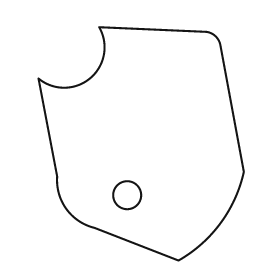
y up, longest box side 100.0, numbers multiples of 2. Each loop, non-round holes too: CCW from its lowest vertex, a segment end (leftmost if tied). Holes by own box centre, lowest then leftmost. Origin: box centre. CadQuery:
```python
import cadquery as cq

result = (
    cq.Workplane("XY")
    .moveTo(16.0, -50.0)
    .threePointArc((34.0, -34.0), (44.0, -12.0))
    .lineTo(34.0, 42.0)
    .threePointArc((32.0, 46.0), (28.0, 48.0))
    .lineTo(-18.0, 50.0)
    .threePointArc((-22.0, 28.0), (-44.0, 28.0))
    .lineTo(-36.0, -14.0)
    .threePointArc((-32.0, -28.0), (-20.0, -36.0))
    .close()
    .moveTo(-6.0, -22.0)
    .circle(6.0)
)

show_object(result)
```